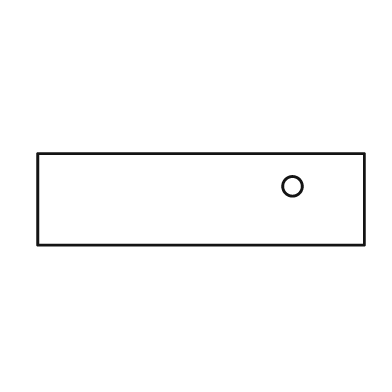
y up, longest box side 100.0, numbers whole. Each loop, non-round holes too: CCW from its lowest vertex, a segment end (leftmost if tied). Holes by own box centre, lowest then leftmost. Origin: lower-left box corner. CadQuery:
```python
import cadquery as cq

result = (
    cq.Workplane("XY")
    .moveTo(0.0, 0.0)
    .lineTo(100.0, 0.0)
    .lineTo(100.0, 28.0)
    .lineTo(0.0, 28.0)
    .close()
    .moveTo(78.0, 18.0)
    .circle(3.0)
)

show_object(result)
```